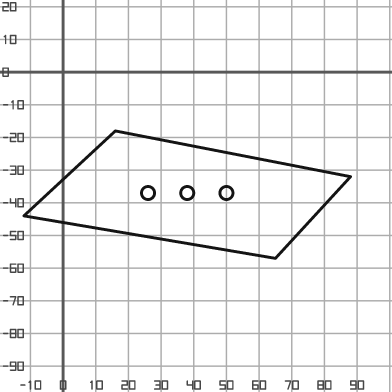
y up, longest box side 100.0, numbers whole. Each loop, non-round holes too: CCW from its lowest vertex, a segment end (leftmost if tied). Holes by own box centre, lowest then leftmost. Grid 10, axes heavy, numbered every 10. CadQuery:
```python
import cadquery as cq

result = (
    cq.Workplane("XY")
    .moveTo(65.0, -57.0)
    .lineTo(88.0, -32.0)
    .lineTo(16.0, -18.0)
    .lineTo(-12.0, -44.0)
    .close()
    .moveTo(26.0, -37.0)
    .circle(2.0)
    .moveTo(38.0, -37.0)
    .circle(2.0)
    .moveTo(50.0, -37.0)
    .circle(2.0)
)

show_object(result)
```